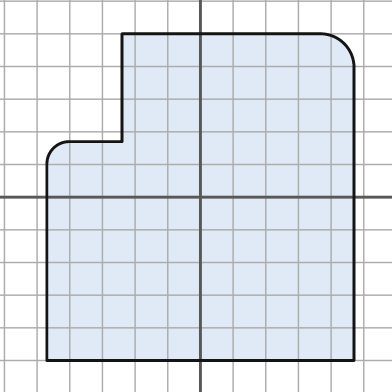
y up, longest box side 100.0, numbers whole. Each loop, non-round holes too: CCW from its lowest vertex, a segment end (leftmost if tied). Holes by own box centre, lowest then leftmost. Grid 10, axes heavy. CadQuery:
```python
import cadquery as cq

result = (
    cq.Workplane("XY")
    .moveTo(-47.0, -50.0)
    .lineTo(47.0, -50.0)
    .lineTo(47.0, 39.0)
    .threePointArc((44.0, 47.0), (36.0, 50.0))
    .lineTo(-24.0, 50.0)
    .lineTo(-24.0, 17.0)
    .lineTo(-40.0, 17.0)
    .threePointArc((-45.0, 15.0), (-47.0, 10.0))
    .close()
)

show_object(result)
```